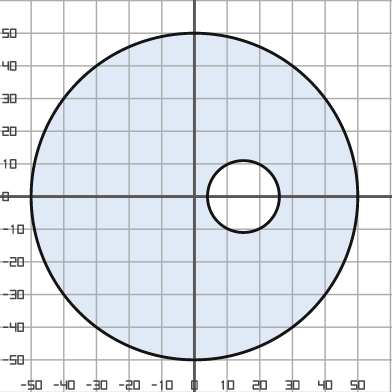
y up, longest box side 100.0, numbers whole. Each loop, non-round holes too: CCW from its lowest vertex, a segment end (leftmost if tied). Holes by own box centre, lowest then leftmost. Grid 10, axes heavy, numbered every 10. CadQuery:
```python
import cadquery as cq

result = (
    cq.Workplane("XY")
    .moveTo(0.0, 0.0)
    .circle(50.0)
    .moveTo(15.0, 0.0)
    .circle(11.0)
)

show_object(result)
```